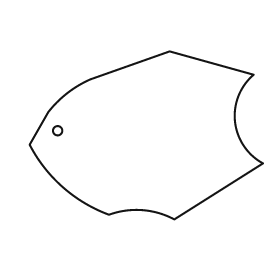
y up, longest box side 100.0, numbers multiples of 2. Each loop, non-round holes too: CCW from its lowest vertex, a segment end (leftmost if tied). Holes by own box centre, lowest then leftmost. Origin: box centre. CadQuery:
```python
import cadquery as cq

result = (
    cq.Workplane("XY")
    .moveTo(12.0, -36.0)
    .lineTo(50.0, -12.0)
    .threePointArc((38.0, 6.0), (46.0, 26.0))
    .lineTo(10.0, 36.0)
    .lineTo(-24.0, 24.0)
    .threePointArc((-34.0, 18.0), (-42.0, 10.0))
    .lineTo(-50.0, -4.0)
    .threePointArc((-36.0, -22.0), (-16.0, -34.0))
    .threePointArc((-2.0, -32.0), (12.0, -36.0))
    .close()
    .moveTo(-38.0, 2.0)
    .circle(2.0)
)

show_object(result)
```